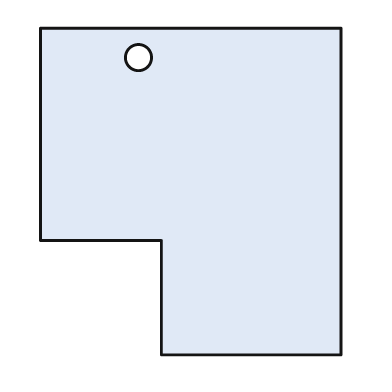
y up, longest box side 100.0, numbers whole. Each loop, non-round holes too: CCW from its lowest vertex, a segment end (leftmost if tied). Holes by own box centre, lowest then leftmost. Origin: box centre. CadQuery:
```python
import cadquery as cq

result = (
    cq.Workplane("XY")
    .moveTo(-9.0, -50.0)
    .lineTo(46.0, -50.0)
    .lineTo(46.0, 50.0)
    .lineTo(-46.0, 50.0)
    .lineTo(-46.0, -15.0)
    .lineTo(-9.0, -15.0)
    .close()
    .moveTo(-16.0, 41.0)
    .circle(4.0)
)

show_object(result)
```